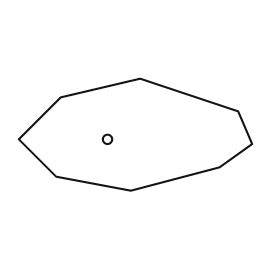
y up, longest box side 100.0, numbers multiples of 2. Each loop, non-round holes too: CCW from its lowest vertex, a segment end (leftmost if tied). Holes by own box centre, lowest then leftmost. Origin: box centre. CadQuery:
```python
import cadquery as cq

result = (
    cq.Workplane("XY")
    .moveTo(-2.0, -24.0)
    .lineTo(36.0, -14.0)
    .lineTo(50.0, -4.0)
    .lineTo(44.0, 10.0)
    .lineTo(2.0, 24.0)
    .lineTo(-32.0, 16.0)
    .lineTo(-50.0, -2.0)
    .lineTo(-34.0, -18.0)
    .close()
    .moveTo(-12.0, -2.0)
    .circle(2.0)
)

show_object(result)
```